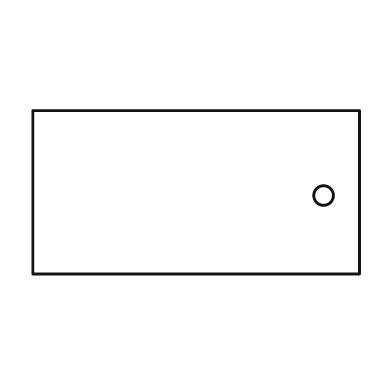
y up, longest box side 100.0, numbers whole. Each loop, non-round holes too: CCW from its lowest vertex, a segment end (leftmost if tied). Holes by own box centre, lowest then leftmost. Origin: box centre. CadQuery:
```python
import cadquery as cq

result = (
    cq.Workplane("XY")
    .moveTo(-50.0, -25.0)
    .lineTo(50.0, -25.0)
    .lineTo(50.0, 25.0)
    .lineTo(-50.0, 25.0)
    .close()
    .moveTo(39.0, -1.0)
    .circle(3.0)
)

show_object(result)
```